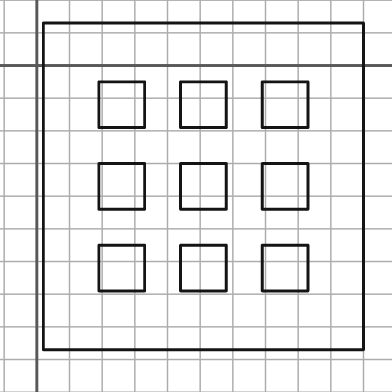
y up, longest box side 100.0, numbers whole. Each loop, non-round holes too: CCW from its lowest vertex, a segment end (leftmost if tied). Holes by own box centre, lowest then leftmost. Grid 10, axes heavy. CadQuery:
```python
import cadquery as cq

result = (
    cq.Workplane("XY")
    .moveTo(2.0, -87.0)
    .lineTo(100.0, -87.0)
    .lineTo(100.0, 13.0)
    .lineTo(2.0, 13.0)
    .close()
    .moveTo(19.0, -69.0)
    .lineTo(33.0, -69.0)
    .lineTo(33.0, -55.0)
    .lineTo(19.0, -55.0)
    .close()
    .moveTo(44.0, -69.0)
    .lineTo(58.0, -69.0)
    .lineTo(58.0, -55.0)
    .lineTo(44.0, -55.0)
    .close()
    .moveTo(69.0, -69.0)
    .lineTo(83.0, -69.0)
    .lineTo(83.0, -55.0)
    .lineTo(69.0, -55.0)
    .close()
    .moveTo(19.0, -44.0)
    .lineTo(33.0, -44.0)
    .lineTo(33.0, -30.0)
    .lineTo(19.0, -30.0)
    .close()
    .moveTo(44.0, -44.0)
    .lineTo(58.0, -44.0)
    .lineTo(58.0, -30.0)
    .lineTo(44.0, -30.0)
    .close()
    .moveTo(69.0, -44.0)
    .lineTo(83.0, -44.0)
    .lineTo(83.0, -30.0)
    .lineTo(69.0, -30.0)
    .close()
    .moveTo(19.0, -19.0)
    .lineTo(33.0, -19.0)
    .lineTo(33.0, -5.0)
    .lineTo(19.0, -5.0)
    .close()
    .moveTo(44.0, -19.0)
    .lineTo(58.0, -19.0)
    .lineTo(58.0, -5.0)
    .lineTo(44.0, -5.0)
    .close()
    .moveTo(69.0, -19.0)
    .lineTo(83.0, -19.0)
    .lineTo(83.0, -5.0)
    .lineTo(69.0, -5.0)
    .close()
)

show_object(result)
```